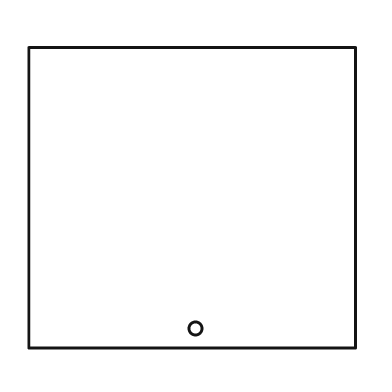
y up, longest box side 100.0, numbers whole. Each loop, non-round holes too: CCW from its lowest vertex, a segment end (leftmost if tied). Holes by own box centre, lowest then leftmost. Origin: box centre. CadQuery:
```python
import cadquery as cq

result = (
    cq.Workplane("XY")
    .moveTo(-50.0, -46.0)
    .lineTo(50.0, -46.0)
    .lineTo(50.0, 46.0)
    .lineTo(-50.0, 46.0)
    .close()
    .moveTo(1.0, -40.0)
    .circle(2.0)
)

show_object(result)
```